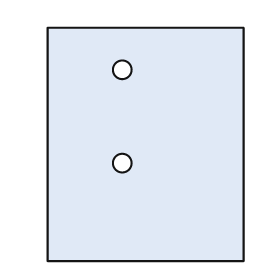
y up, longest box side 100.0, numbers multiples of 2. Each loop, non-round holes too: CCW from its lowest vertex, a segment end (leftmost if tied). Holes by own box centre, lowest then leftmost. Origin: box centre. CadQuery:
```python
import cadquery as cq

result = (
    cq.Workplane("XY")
    .moveTo(-42.0, -50.0)
    .lineTo(42.0, -50.0)
    .lineTo(42.0, 50.0)
    .lineTo(-42.0, 50.0)
    .close()
    .moveTo(-10.0, -8.0)
    .circle(4.0)
    .moveTo(-10.0, 32.0)
    .circle(4.0)
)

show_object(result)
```